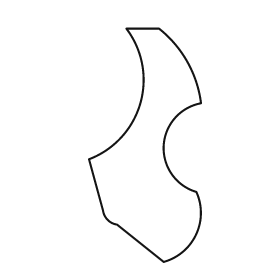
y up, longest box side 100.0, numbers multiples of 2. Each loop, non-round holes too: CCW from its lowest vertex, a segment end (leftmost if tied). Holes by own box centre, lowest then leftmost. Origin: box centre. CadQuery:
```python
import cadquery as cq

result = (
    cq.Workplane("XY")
    .moveTo(8.0, -50.0)
    .threePointArc((22.0, -38.0), (22.0, -20.0))
    .threePointArc((8.0, 0.0), (24.0, 18.0))
    .threePointArc((18.0, 36.0), (6.0, 50.0))
    .lineTo(-8.0, 50.0)
    .threePointArc((-2.0, 18.0), (-24.0, -6.0))
    .lineTo(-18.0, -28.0)
    .threePointArc((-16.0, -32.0), (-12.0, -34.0))
    .close()
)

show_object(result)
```